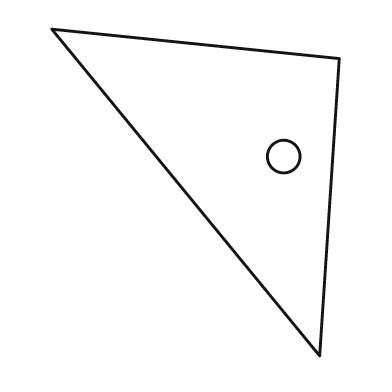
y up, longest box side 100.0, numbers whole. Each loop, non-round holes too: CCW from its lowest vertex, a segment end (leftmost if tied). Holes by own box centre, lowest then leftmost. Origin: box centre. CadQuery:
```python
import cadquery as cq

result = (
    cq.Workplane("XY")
    .moveTo(38.0, -50.0)
    .lineTo(44.0, 41.0)
    .lineTo(-44.0, 50.0)
    .close()
    .moveTo(27.0, 11.0)
    .circle(5.0)
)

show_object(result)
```